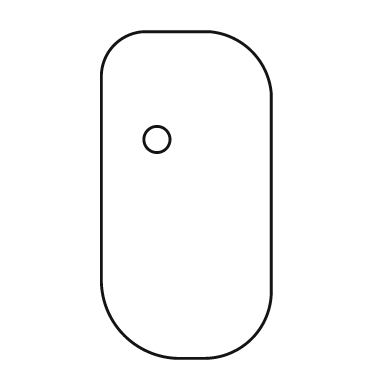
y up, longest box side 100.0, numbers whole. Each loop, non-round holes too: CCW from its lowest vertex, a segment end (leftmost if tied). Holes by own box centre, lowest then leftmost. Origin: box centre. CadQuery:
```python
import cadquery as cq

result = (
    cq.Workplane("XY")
    .moveTo(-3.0, -50.0)
    .lineTo(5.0, -50.0)
    .threePointArc((20.0, -44.0), (26.0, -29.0))
    .lineTo(26.0, 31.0)
    .threePointArc((20.0, 44.0), (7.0, 50.0))
    .lineTo(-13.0, 50.0)
    .threePointArc((-22.0, 46.0), (-26.0, 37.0))
    .lineTo(-26.0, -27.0)
    .threePointArc((-19.0, -43.0), (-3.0, -50.0))
    .close()
    .moveTo(-9.0, 17.0)
    .circle(4.0)
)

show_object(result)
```